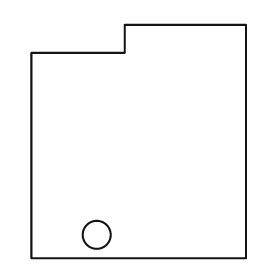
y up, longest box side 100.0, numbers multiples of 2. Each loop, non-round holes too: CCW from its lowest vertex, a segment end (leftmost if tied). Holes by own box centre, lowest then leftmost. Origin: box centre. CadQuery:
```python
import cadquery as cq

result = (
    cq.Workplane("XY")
    .moveTo(-46.0, -50.0)
    .lineTo(46.0, -50.0)
    .lineTo(46.0, 50.0)
    .lineTo(-6.0, 50.0)
    .lineTo(-6.0, 38.0)
    .lineTo(-46.0, 38.0)
    .close()
    .moveTo(-18.0, -40.0)
    .circle(6.0)
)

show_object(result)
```